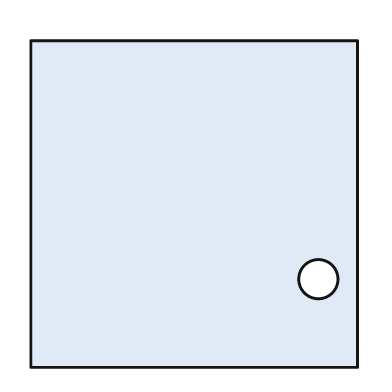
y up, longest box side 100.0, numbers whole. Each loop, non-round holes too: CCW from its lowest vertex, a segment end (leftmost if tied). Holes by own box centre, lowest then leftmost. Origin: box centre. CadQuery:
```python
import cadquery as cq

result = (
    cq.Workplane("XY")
    .moveTo(-50.0, -50.0)
    .lineTo(50.0, -50.0)
    .lineTo(50.0, 50.0)
    .lineTo(-50.0, 50.0)
    .close()
    .moveTo(38.0, -23.0)
    .circle(6.0)
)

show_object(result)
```